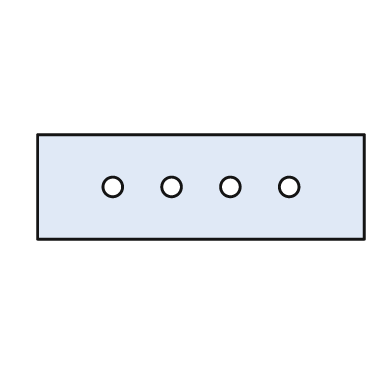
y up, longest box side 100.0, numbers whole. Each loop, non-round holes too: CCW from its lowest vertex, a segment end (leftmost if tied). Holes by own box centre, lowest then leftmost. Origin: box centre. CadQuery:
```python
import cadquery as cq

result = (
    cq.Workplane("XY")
    .moveTo(-50.0, -16.0)
    .lineTo(50.0, -16.0)
    .lineTo(50.0, 16.0)
    .lineTo(-50.0, 16.0)
    .close()
    .moveTo(-27.0, 0.0)
    .circle(3.0)
    .moveTo(-9.0, 0.0)
    .circle(3.0)
    .moveTo(9.0, 0.0)
    .circle(3.0)
    .moveTo(27.0, 0.0)
    .circle(3.0)
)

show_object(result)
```